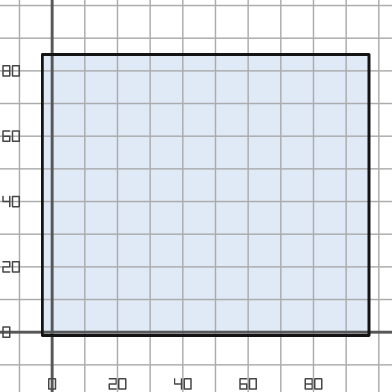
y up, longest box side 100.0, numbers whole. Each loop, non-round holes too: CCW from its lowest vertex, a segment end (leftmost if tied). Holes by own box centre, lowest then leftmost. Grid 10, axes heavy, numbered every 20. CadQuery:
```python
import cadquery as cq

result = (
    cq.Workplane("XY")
    .moveTo(-3.0, -1.0)
    .lineTo(97.0, -1.0)
    .lineTo(97.0, 85.0)
    .lineTo(-3.0, 85.0)
    .close()
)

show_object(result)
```